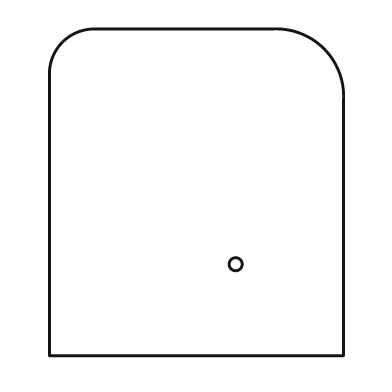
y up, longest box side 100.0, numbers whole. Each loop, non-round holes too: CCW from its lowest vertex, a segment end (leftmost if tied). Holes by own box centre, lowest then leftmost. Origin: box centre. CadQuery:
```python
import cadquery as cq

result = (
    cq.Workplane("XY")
    .moveTo(-45.0, -50.0)
    .lineTo(45.0, -50.0)
    .lineTo(45.0, 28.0)
    .threePointArc((39.0, 44.0), (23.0, 50.0))
    .lineTo(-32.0, 50.0)
    .threePointArc((-41.0, 46.0), (-45.0, 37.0))
    .close()
    .moveTo(12.0, -22.0)
    .circle(2.0)
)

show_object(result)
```